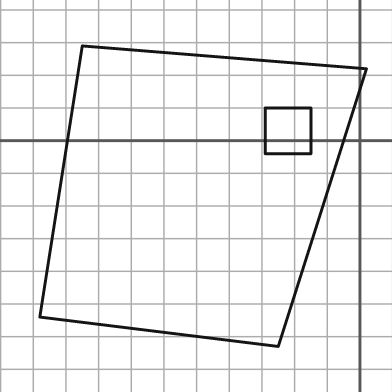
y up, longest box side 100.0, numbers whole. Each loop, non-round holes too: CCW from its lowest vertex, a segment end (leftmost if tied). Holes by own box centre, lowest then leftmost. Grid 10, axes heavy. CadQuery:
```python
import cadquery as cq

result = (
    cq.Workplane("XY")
    .moveTo(-25.0, -63.0)
    .lineTo(2.0, 22.0)
    .lineTo(-85.0, 29.0)
    .lineTo(-98.0, -54.0)
    .close()
    .moveTo(-29.0, -4.0)
    .lineTo(-15.0, -4.0)
    .lineTo(-15.0, 10.0)
    .lineTo(-29.0, 10.0)
    .close()
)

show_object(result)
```